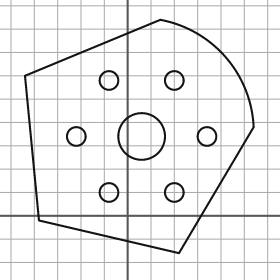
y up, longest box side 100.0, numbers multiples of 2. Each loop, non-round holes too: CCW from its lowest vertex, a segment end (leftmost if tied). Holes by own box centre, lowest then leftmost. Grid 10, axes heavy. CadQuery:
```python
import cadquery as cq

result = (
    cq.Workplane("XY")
    .moveTo(22.0, -16.0)
    .lineTo(54.0, 38.0)
    .threePointArc((42.0, 68.0), (14.0, 84.0))
    .lineTo(-44.0, 60.0)
    .lineTo(-38.0, -2.0)
    .close()
    .moveTo(-8.0, 10.0)
    .circle(4.0)
    .moveTo(20.0, 10.0)
    .circle(4.0)
    .moveTo(-22.0, 34.0)
    .circle(4.0)
    .moveTo(6.0, 34.0)
    .circle(10.0)
    .moveTo(34.0, 34.0)
    .circle(4.0)
    .moveTo(-8.0, 58.0)
    .circle(4.0)
    .moveTo(20.0, 58.0)
    .circle(4.0)
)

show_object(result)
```